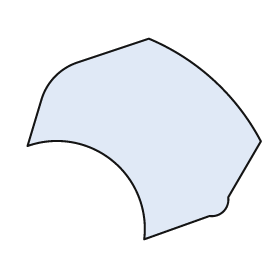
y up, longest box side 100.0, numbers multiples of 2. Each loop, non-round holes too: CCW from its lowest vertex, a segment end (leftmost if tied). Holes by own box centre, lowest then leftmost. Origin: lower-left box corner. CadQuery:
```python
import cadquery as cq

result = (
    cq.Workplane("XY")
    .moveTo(50.0, 0.0)
    .lineTo(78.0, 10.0)
    .threePointArc((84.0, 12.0), (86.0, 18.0))
    .lineTo(100.0, 42.0)
    .threePointArc((80.0, 68.0), (52.0, 86.0))
    .lineTo(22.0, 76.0)
    .threePointArc((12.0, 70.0), (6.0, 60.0))
    .lineTo(0.0, 40.0)
    .threePointArc((36.0, 34.0), (50.0, 0.0))
    .close()
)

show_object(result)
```